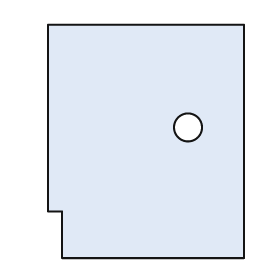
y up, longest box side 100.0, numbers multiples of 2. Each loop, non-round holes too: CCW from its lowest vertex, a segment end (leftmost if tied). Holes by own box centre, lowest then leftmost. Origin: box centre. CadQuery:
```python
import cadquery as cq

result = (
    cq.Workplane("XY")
    .moveTo(-36.0, -50.0)
    .lineTo(42.0, -50.0)
    .lineTo(42.0, 50.0)
    .lineTo(-42.0, 50.0)
    .lineTo(-42.0, -30.0)
    .lineTo(-36.0, -30.0)
    .close()
    .moveTo(18.0, 6.0)
    .circle(6.0)
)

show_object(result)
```